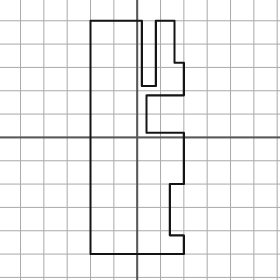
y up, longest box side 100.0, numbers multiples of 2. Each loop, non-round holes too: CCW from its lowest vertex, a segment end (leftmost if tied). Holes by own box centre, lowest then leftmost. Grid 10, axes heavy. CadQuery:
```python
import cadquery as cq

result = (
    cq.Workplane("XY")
    .moveTo(-20.0, -50.0)
    .lineTo(20.0, -50.0)
    .lineTo(20.0, -42.0)
    .lineTo(14.0, -42.0)
    .lineTo(14.0, -20.0)
    .lineTo(20.0, -20.0)
    .lineTo(20.0, 2.0)
    .lineTo(4.0, 2.0)
    .lineTo(4.0, 18.0)
    .lineTo(20.0, 18.0)
    .lineTo(20.0, 32.0)
    .lineTo(16.0, 32.0)
    .lineTo(16.0, 50.0)
    .lineTo(8.0, 50.0)
    .lineTo(8.0, 22.0)
    .lineTo(2.0, 22.0)
    .lineTo(2.0, 50.0)
    .lineTo(-20.0, 50.0)
    .close()
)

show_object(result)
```